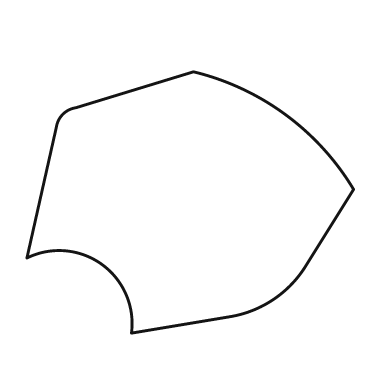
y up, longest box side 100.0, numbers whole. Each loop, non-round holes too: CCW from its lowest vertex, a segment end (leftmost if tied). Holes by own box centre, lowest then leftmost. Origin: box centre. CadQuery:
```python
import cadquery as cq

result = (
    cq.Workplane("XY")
    .moveTo(-18.0, -40.0)
    .lineTo(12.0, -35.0)
    .threePointArc((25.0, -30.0), (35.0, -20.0))
    .lineTo(50.0, 4.0)
    .threePointArc((29.0, 27.0), (1.0, 40.0))
    .lineTo(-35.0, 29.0)
    .threePointArc((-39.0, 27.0), (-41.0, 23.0))
    .lineTo(-50.0, -17.0)
    .threePointArc((-27.0, -19.0), (-18.0, -40.0))
    .close()
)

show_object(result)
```